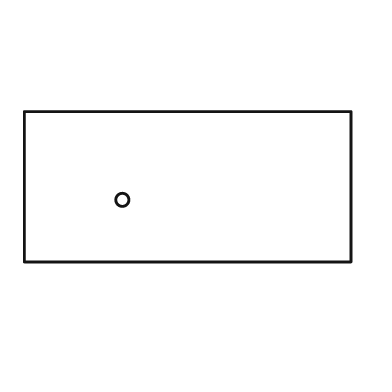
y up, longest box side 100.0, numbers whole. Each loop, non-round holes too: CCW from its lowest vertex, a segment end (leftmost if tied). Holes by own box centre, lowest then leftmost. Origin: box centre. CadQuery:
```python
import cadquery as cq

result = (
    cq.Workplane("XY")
    .moveTo(-50.0, -23.0)
    .lineTo(50.0, -23.0)
    .lineTo(50.0, 23.0)
    .lineTo(-50.0, 23.0)
    .close()
    .moveTo(-20.0, -4.0)
    .circle(2.0)
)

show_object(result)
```